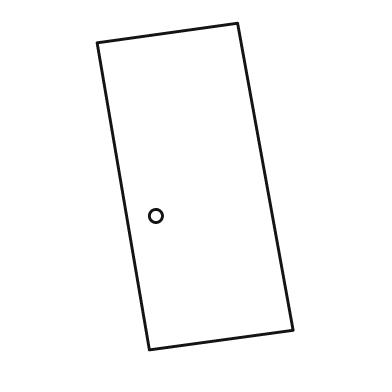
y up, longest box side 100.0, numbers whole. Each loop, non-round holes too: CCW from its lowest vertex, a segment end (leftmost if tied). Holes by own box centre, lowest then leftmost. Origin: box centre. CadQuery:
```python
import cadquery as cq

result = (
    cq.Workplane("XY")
    .moveTo(-14.0, -50.0)
    .lineTo(30.0, -44.0)
    .lineTo(13.0, 50.0)
    .lineTo(-30.0, 44.0)
    .close()
    .moveTo(-12.0, -9.0)
    .circle(2.0)
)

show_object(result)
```